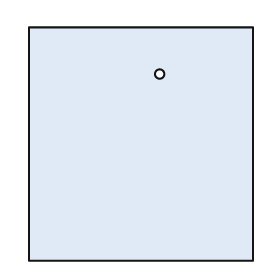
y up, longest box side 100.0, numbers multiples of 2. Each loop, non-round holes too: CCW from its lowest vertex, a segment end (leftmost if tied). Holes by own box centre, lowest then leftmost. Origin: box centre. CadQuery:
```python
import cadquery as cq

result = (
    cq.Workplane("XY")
    .moveTo(-48.0, -50.0)
    .lineTo(48.0, -50.0)
    .lineTo(48.0, 50.0)
    .lineTo(-48.0, 50.0)
    .close()
    .moveTo(8.0, 30.0)
    .circle(2.0)
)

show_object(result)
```